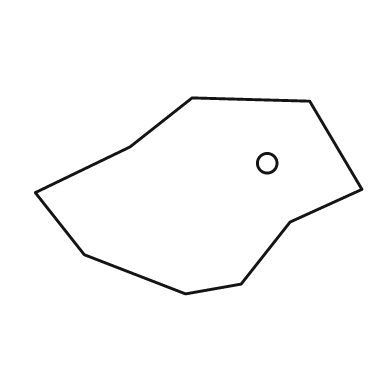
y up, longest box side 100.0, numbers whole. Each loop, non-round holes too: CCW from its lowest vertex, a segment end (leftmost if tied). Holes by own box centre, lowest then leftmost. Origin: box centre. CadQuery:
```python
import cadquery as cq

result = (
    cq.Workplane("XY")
    .moveTo(-4.0, -30.0)
    .lineTo(13.0, -27.0)
    .lineTo(28.0, -8.0)
    .lineTo(50.0, 2.0)
    .lineTo(34.0, 29.0)
    .lineTo(-2.0, 30.0)
    .lineTo(-21.0, 15.0)
    .lineTo(-50.0, 1.0)
    .lineTo(-35.0, -18.0)
    .close()
    .moveTo(21.0, 10.0)
    .circle(3.0)
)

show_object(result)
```